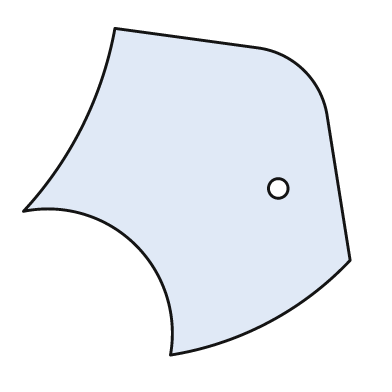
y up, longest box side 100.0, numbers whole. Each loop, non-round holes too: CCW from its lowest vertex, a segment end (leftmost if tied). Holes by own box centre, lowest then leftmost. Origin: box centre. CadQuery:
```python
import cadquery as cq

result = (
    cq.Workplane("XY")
    .moveTo(-5.0, -50.0)
    .threePointArc((25.0, -40.0), (50.0, -21.0))
    .lineTo(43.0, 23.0)
    .threePointArc((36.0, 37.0), (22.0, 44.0))
    .lineTo(-22.0, 50.0)
    .threePointArc((-32.0, 20.0), (-50.0, -6.0))
    .threePointArc((-16.0, -16.0), (-5.0, -50.0))
    .close()
    .moveTo(28.0, 1.0)
    .circle(3.0)
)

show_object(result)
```